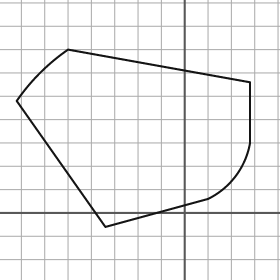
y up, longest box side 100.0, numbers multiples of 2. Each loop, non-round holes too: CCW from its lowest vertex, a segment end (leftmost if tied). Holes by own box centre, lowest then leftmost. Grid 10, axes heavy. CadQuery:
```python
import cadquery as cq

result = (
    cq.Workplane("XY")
    .moveTo(-34.0, -6.0)
    .lineTo(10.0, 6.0)
    .threePointArc((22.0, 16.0), (28.0, 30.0))
    .lineTo(28.0, 56.0)
    .lineTo(-50.0, 70.0)
    .threePointArc((-62.0, 60.0), (-72.0, 48.0))
    .close()
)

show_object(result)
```